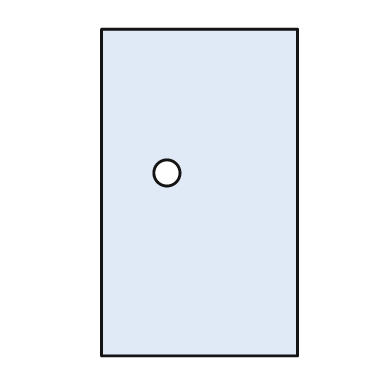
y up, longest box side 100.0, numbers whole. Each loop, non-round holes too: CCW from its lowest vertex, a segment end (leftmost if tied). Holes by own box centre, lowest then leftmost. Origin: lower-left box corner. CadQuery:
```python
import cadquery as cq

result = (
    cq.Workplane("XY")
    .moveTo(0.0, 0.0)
    .lineTo(60.0, 0.0)
    .lineTo(60.0, 100.0)
    .lineTo(0.0, 100.0)
    .close()
    .moveTo(20.0, 56.0)
    .circle(4.0)
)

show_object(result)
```